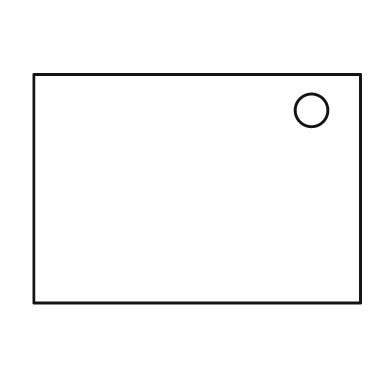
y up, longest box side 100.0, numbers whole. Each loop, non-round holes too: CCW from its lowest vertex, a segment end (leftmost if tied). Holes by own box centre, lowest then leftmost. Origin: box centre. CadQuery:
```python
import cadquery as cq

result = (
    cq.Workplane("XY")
    .moveTo(-50.0, -35.0)
    .lineTo(50.0, -35.0)
    .lineTo(50.0, 35.0)
    .lineTo(-50.0, 35.0)
    .close()
    .moveTo(35.0, 24.0)
    .circle(5.0)
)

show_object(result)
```